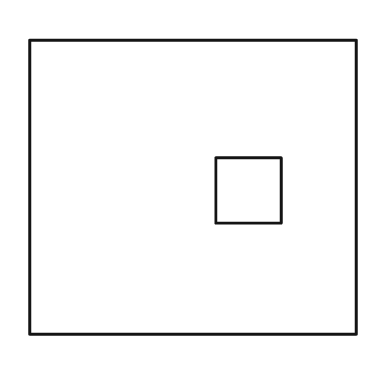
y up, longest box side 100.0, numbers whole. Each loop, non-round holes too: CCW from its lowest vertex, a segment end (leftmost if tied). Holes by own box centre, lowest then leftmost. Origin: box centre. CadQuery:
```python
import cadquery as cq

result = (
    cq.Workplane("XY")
    .moveTo(-50.0, -45.0)
    .lineTo(50.0, -45.0)
    .lineTo(50.0, 45.0)
    .lineTo(-50.0, 45.0)
    .close()
    .moveTo(7.0, -11.0)
    .lineTo(27.0, -11.0)
    .lineTo(27.0, 9.0)
    .lineTo(7.0, 9.0)
    .close()
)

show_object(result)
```